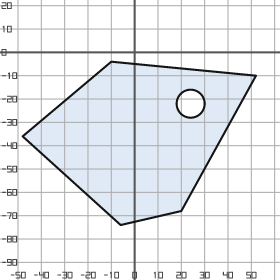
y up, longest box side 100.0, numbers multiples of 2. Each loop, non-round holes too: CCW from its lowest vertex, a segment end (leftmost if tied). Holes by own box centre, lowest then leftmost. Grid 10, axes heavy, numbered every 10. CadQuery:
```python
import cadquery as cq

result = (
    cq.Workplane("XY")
    .moveTo(-6.0, -74.0)
    .lineTo(20.0, -68.0)
    .lineTo(52.0, -10.0)
    .lineTo(-10.0, -4.0)
    .lineTo(-48.0, -36.0)
    .close()
    .moveTo(24.0, -22.0)
    .circle(6.0)
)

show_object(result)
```